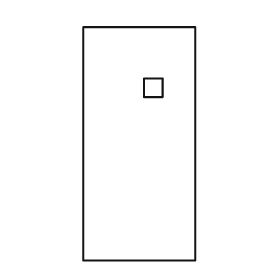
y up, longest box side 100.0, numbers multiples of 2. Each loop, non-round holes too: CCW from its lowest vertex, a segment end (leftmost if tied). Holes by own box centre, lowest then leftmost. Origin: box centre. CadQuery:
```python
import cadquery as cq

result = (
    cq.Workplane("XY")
    .moveTo(-24.0, -50.0)
    .lineTo(24.0, -50.0)
    .lineTo(24.0, 50.0)
    .lineTo(-24.0, 50.0)
    .close()
    .moveTo(2.0, 20.0)
    .lineTo(10.0, 20.0)
    .lineTo(10.0, 28.0)
    .lineTo(2.0, 28.0)
    .close()
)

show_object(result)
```